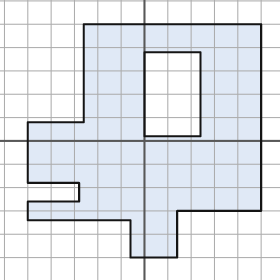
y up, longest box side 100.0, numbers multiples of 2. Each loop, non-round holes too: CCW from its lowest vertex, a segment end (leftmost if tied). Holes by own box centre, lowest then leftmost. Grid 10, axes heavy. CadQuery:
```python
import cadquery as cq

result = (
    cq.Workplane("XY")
    .moveTo(-6.0, -50.0)
    .lineTo(14.0, -50.0)
    .lineTo(14.0, -30.0)
    .lineTo(50.0, -30.0)
    .lineTo(50.0, 50.0)
    .lineTo(-26.0, 50.0)
    .lineTo(-26.0, 8.0)
    .lineTo(-50.0, 8.0)
    .lineTo(-50.0, -18.0)
    .lineTo(-28.0, -18.0)
    .lineTo(-28.0, -26.0)
    .lineTo(-50.0, -26.0)
    .lineTo(-50.0, -34.0)
    .lineTo(-6.0, -34.0)
    .close()
    .moveTo(0.0, 2.0)
    .lineTo(24.0, 2.0)
    .lineTo(24.0, 38.0)
    .lineTo(0.0, 38.0)
    .close()
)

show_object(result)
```